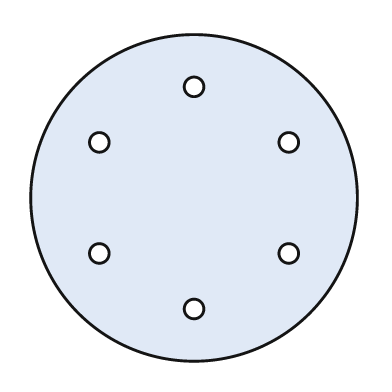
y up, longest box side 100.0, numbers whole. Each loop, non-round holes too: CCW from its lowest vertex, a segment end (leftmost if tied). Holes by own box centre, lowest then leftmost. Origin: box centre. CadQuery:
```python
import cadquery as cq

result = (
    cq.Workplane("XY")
    .moveTo(0.0, 0.0)
    .circle(50.0)
    .moveTo(0.0, -34.0)
    .circle(3.0)
    .moveTo(-29.0, -17.0)
    .circle(3.0)
    .moveTo(29.0, -17.0)
    .circle(3.0)
    .moveTo(-29.0, 17.0)
    .circle(3.0)
    .moveTo(29.0, 17.0)
    .circle(3.0)
    .moveTo(0.0, 34.0)
    .circle(3.0)
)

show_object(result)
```